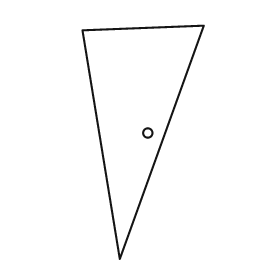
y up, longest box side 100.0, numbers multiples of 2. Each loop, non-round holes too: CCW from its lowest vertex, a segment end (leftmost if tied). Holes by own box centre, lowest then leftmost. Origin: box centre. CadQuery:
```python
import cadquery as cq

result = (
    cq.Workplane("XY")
    .moveTo(-10.0, -50.0)
    .lineTo(26.0, 50.0)
    .lineTo(-26.0, 48.0)
    .close()
    .moveTo(2.0, 4.0)
    .circle(2.0)
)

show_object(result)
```